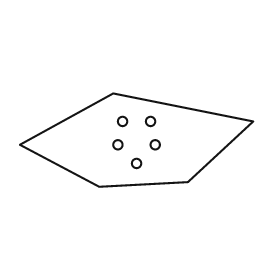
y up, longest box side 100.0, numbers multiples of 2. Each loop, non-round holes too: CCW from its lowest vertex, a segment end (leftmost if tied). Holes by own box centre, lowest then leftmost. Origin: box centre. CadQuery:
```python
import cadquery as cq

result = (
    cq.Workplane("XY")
    .moveTo(-16.0, -20.0)
    .lineTo(22.0, -18.0)
    .lineTo(50.0, 8.0)
    .lineTo(-10.0, 20.0)
    .lineTo(-50.0, -2.0)
    .close()
    .moveTo(0.0, -10.0)
    .circle(2.0)
    .moveTo(-8.0, -2.0)
    .circle(2.0)
    .moveTo(8.0, -2.0)
    .circle(2.0)
    .moveTo(-6.0, 8.0)
    .circle(2.0)
    .moveTo(6.0, 8.0)
    .circle(2.0)
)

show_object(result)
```